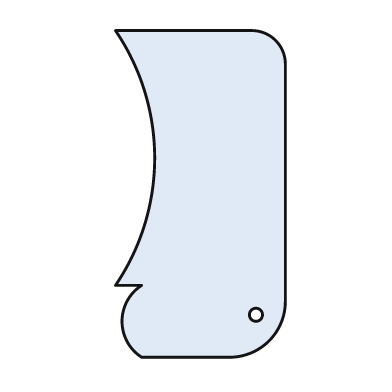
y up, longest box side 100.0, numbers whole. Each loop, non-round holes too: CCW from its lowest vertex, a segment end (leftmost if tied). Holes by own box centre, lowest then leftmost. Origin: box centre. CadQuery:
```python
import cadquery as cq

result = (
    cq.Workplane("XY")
    .moveTo(-18.0, -50.0)
    .lineTo(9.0, -50.0)
    .threePointArc((21.0, -45.0), (26.0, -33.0))
    .lineTo(26.0, 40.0)
    .threePointArc((23.0, 47.0), (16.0, 50.0))
    .lineTo(-26.0, 50.0)
    .threePointArc((-14.0, 11.0), (-26.0, -28.0))
    .lineTo(-18.0, -28.0)
    .threePointArc((-24.0, -39.0), (-18.0, -50.0))
    .close()
    .moveTo(17.0, -37.0)
    .circle(2.0)
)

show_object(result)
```